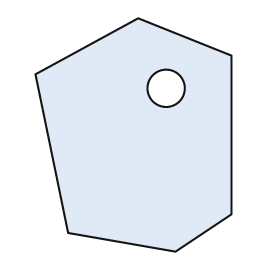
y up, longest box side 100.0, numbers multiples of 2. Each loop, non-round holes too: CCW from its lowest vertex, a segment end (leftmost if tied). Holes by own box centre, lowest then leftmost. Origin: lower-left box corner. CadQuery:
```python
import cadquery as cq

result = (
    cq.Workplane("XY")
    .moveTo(60.0, 0.0)
    .lineTo(84.0, 16.0)
    .lineTo(84.0, 84.0)
    .lineTo(44.0, 100.0)
    .lineTo(0.0, 76.0)
    .lineTo(14.0, 8.0)
    .close()
    .moveTo(56.0, 70.0)
    .circle(8.0)
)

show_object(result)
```